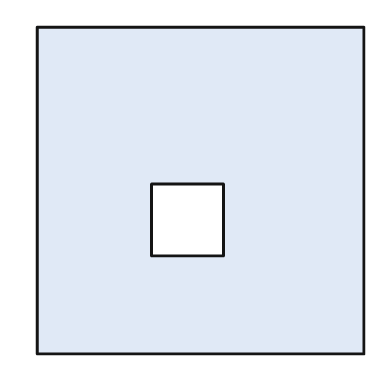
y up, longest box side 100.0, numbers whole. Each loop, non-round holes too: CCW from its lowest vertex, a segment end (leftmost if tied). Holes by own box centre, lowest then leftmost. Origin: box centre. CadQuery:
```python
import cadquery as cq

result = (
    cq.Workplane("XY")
    .moveTo(-50.0, -50.0)
    .lineTo(50.0, -50.0)
    .lineTo(50.0, 50.0)
    .lineTo(-50.0, 50.0)
    .close()
    .moveTo(-15.0, -20.0)
    .lineTo(7.0, -20.0)
    .lineTo(7.0, 2.0)
    .lineTo(-15.0, 2.0)
    .close()
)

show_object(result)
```